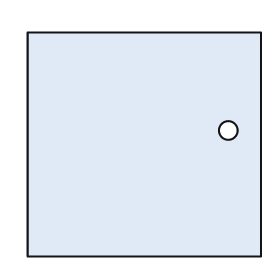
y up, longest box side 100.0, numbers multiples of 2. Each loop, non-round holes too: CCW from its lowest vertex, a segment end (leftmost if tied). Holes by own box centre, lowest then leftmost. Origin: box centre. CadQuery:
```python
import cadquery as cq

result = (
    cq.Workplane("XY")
    .moveTo(-50.0, -48.0)
    .lineTo(50.0, -48.0)
    .lineTo(50.0, 48.0)
    .lineTo(-50.0, 48.0)
    .close()
    .moveTo(36.0, 6.0)
    .circle(4.0)
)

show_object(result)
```